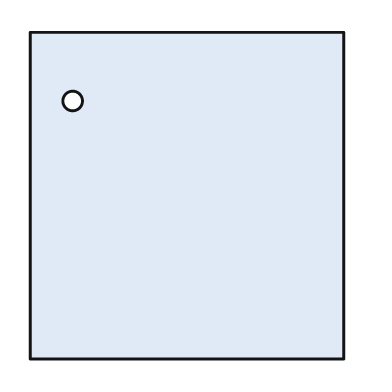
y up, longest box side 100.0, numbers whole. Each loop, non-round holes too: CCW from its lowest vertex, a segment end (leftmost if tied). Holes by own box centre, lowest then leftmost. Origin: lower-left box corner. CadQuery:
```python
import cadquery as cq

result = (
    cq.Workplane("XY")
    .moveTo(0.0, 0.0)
    .lineTo(96.0, 0.0)
    .lineTo(96.0, 100.0)
    .lineTo(0.0, 100.0)
    .close()
    .moveTo(13.0, 79.0)
    .circle(3.0)
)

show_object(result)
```